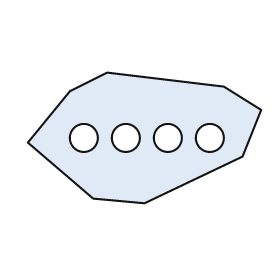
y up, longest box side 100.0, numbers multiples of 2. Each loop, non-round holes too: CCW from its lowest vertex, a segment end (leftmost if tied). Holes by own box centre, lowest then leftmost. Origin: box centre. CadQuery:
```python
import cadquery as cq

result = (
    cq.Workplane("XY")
    .moveTo(0.0, -28.0)
    .lineTo(42.0, -8.0)
    .lineTo(50.0, 12.0)
    .lineTo(34.0, 22.0)
    .lineTo(-16.0, 28.0)
    .lineTo(-32.0, 20.0)
    .lineTo(-50.0, -2.0)
    .lineTo(-22.0, -26.0)
    .close()
    .moveTo(-26.0, 0.0)
    .circle(6.0)
    .moveTo(-8.0, 0.0)
    .circle(6.0)
    .moveTo(10.0, 0.0)
    .circle(6.0)
    .moveTo(28.0, 0.0)
    .circle(6.0)
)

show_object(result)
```